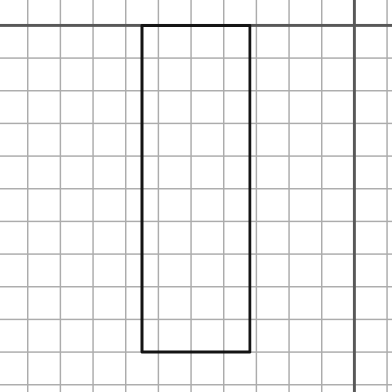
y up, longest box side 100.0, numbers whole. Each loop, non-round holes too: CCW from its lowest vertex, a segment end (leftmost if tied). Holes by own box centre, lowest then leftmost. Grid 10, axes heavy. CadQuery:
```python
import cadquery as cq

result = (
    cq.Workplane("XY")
    .moveTo(-65.0, -100.0)
    .lineTo(-32.0, -100.0)
    .lineTo(-32.0, 0.0)
    .lineTo(-65.0, 0.0)
    .close()
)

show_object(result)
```